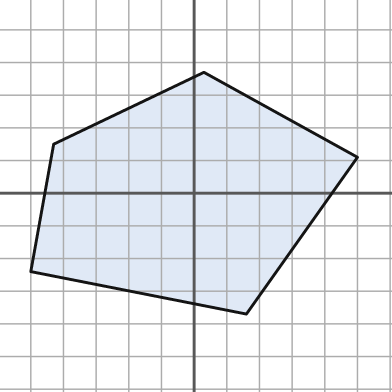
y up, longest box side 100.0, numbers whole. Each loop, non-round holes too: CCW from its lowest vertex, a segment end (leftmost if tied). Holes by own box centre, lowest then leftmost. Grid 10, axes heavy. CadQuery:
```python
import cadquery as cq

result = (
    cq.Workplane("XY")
    .moveTo(16.0, -37.0)
    .lineTo(50.0, 11.0)
    .lineTo(3.0, 37.0)
    .lineTo(-43.0, 15.0)
    .lineTo(-50.0, -24.0)
    .close()
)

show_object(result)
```